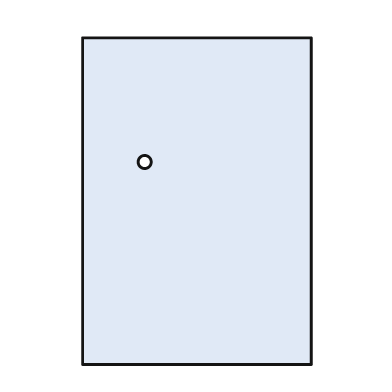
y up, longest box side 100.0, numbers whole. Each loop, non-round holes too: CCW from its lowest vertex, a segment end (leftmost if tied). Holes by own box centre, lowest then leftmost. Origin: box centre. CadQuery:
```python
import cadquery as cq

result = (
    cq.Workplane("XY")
    .moveTo(-35.0, -50.0)
    .lineTo(35.0, -50.0)
    .lineTo(35.0, 50.0)
    .lineTo(-35.0, 50.0)
    .close()
    .moveTo(-16.0, 12.0)
    .circle(2.0)
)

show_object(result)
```